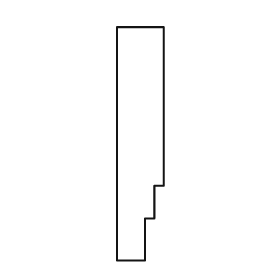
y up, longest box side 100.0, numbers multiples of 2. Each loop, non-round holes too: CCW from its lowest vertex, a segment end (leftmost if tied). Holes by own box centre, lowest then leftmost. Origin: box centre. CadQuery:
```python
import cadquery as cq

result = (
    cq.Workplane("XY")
    .moveTo(-10.0, -50.0)
    .lineTo(2.0, -50.0)
    .lineTo(2.0, -32.0)
    .lineTo(6.0, -32.0)
    .lineTo(6.0, -18.0)
    .lineTo(10.0, -18.0)
    .lineTo(10.0, 50.0)
    .lineTo(-10.0, 50.0)
    .close()
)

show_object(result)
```